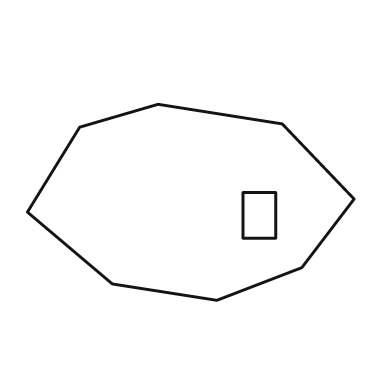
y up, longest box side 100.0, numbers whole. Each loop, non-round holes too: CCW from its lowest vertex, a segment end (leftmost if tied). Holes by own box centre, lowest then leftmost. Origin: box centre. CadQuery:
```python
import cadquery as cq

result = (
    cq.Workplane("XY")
    .moveTo(8.0, -30.0)
    .lineTo(34.0, -20.0)
    .lineTo(50.0, 1.0)
    .lineTo(28.0, 24.0)
    .lineTo(-10.0, 30.0)
    .lineTo(-34.0, 23.0)
    .lineTo(-50.0, -3.0)
    .lineTo(-24.0, -25.0)
    .close()
    .moveTo(16.0, -11.0)
    .lineTo(26.0, -11.0)
    .lineTo(26.0, 3.0)
    .lineTo(16.0, 3.0)
    .close()
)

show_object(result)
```